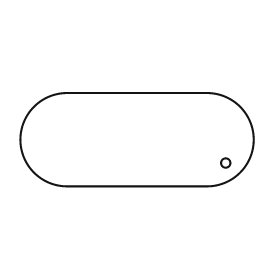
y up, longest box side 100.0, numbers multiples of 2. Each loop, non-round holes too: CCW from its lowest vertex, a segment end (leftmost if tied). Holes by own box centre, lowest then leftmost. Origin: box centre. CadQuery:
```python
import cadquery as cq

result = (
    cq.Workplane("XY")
    .moveTo(-30.0, -20.0)
    .lineTo(30.0, -20.0)
    .threePointArc((50.0, 0.0), (30.0, 20.0))
    .lineTo(-30.0, 20.0)
    .threePointArc((-50.0, 0.0), (-30.0, -20.0))
    .close()
    .moveTo(38.0, -10.0)
    .circle(2.0)
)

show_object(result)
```